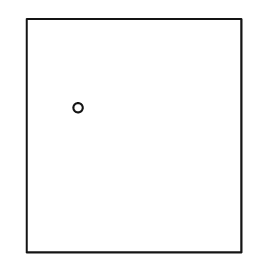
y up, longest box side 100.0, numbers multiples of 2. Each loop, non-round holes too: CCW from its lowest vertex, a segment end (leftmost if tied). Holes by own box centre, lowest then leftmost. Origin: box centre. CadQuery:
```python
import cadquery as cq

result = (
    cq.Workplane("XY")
    .moveTo(-46.0, -50.0)
    .lineTo(46.0, -50.0)
    .lineTo(46.0, 50.0)
    .lineTo(-46.0, 50.0)
    .close()
    .moveTo(-24.0, 12.0)
    .circle(2.0)
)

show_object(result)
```